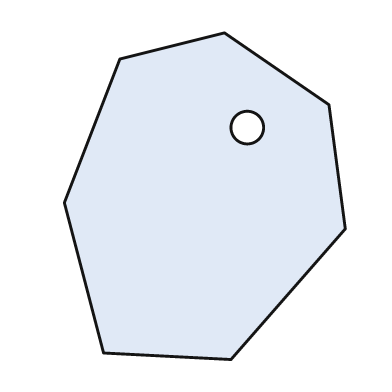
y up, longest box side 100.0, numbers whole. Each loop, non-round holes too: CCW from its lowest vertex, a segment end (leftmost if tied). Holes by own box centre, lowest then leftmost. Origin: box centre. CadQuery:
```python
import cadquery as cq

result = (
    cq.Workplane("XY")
    .moveTo(8.0, -50.0)
    .lineTo(43.0, -10.0)
    .lineTo(38.0, 28.0)
    .lineTo(6.0, 50.0)
    .lineTo(-26.0, 42.0)
    .lineTo(-43.0, -2.0)
    .lineTo(-31.0, -48.0)
    .close()
    .moveTo(13.0, 21.0)
    .circle(5.0)
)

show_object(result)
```